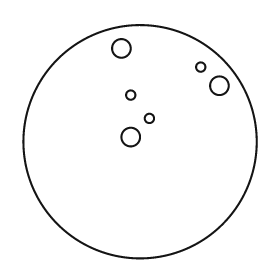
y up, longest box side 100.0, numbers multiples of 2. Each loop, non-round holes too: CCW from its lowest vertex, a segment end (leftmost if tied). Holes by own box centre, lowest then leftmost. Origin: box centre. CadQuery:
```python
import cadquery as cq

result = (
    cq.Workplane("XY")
    .moveTo(0.0, 0.0)
    .circle(50.0)
    .moveTo(-4.0, 2.0)
    .circle(4.0)
    .moveTo(4.0, 10.0)
    .circle(2.0)
    .moveTo(-4.0, 20.0)
    .circle(2.0)
    .moveTo(34.0, 24.0)
    .circle(4.0)
    .moveTo(26.0, 32.0)
    .circle(2.0)
    .moveTo(-8.0, 40.0)
    .circle(4.0)
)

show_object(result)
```